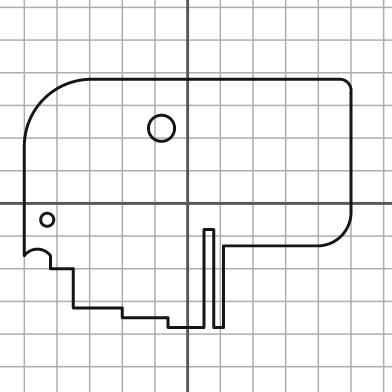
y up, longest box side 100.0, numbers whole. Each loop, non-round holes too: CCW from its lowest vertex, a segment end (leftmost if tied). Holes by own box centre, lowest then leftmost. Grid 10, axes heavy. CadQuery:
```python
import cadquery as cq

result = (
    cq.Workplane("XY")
    .moveTo(-6.0, -38.0)
    .lineTo(5.0, -38.0)
    .lineTo(5.0, -8.0)
    .lineTo(8.0, -8.0)
    .lineTo(8.0, -38.0)
    .lineTo(11.0, -38.0)
    .lineTo(11.0, -13.0)
    .lineTo(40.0, -13.0)
    .threePointArc((47.0, -10.0), (50.0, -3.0))
    .lineTo(50.0, 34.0)
    .threePointArc((49.0, 37.0), (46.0, 38.0))
    .lineTo(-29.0, 38.0)
    .threePointArc((-44.0, 32.0), (-50.0, 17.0))
    .lineTo(-50.0, -16.0)
    .threePointArc((-46.0, -14.0), (-42.0, -16.0))
    .lineTo(-42.0, -20.0)
    .lineTo(-35.0, -20.0)
    .lineTo(-35.0, -32.0)
    .lineTo(-20.0, -32.0)
    .lineTo(-20.0, -35.0)
    .lineTo(-6.0, -35.0)
    .close()
    .moveTo(-43.0, -5.0)
    .circle(2.0)
    .moveTo(-8.0, 23.0)
    .circle(4.0)
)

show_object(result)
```